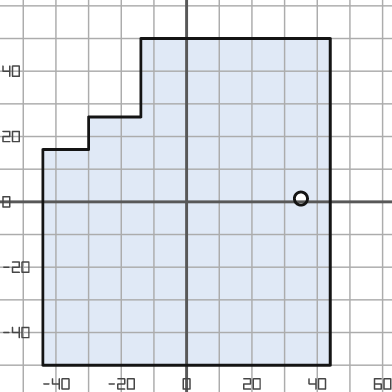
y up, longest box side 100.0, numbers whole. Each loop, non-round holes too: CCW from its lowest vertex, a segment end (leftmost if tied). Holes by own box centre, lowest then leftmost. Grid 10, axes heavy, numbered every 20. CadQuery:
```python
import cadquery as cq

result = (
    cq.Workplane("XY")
    .moveTo(-44.0, -50.0)
    .lineTo(44.0, -50.0)
    .lineTo(44.0, 50.0)
    .lineTo(-14.0, 50.0)
    .lineTo(-14.0, 26.0)
    .lineTo(-30.0, 26.0)
    .lineTo(-30.0, 16.0)
    .lineTo(-44.0, 16.0)
    .close()
    .moveTo(35.0, 1.0)
    .circle(2.0)
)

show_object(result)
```